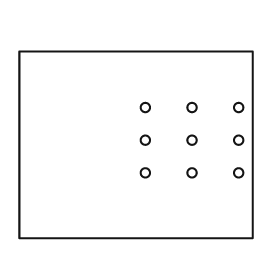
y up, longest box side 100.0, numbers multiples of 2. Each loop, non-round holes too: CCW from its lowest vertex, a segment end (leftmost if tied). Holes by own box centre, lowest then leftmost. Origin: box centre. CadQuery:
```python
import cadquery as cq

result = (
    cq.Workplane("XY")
    .moveTo(-50.0, -40.0)
    .lineTo(50.0, -40.0)
    .lineTo(50.0, 40.0)
    .lineTo(-50.0, 40.0)
    .close()
    .moveTo(4.0, -12.0)
    .circle(2.0)
    .moveTo(24.0, -12.0)
    .circle(2.0)
    .moveTo(44.0, -12.0)
    .circle(2.0)
    .moveTo(4.0, 2.0)
    .circle(2.0)
    .moveTo(24.0, 2.0)
    .circle(2.0)
    .moveTo(44.0, 2.0)
    .circle(2.0)
    .moveTo(4.0, 16.0)
    .circle(2.0)
    .moveTo(24.0, 16.0)
    .circle(2.0)
    .moveTo(44.0, 16.0)
    .circle(2.0)
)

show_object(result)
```